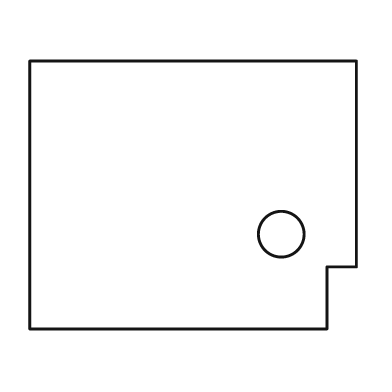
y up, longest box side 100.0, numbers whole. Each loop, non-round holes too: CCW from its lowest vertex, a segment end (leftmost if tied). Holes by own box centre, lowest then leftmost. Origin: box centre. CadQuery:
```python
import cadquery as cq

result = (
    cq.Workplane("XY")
    .moveTo(-50.0, -41.0)
    .lineTo(41.0, -41.0)
    .lineTo(41.0, -22.0)
    .lineTo(50.0, -22.0)
    .lineTo(50.0, 41.0)
    .lineTo(-50.0, 41.0)
    .close()
    .moveTo(27.0, -12.0)
    .circle(7.0)
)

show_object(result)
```